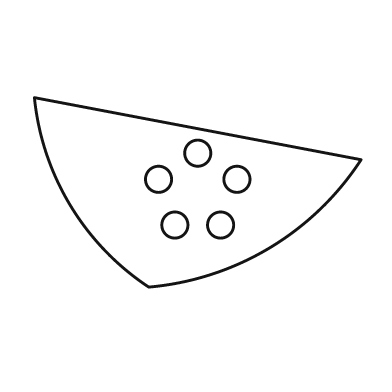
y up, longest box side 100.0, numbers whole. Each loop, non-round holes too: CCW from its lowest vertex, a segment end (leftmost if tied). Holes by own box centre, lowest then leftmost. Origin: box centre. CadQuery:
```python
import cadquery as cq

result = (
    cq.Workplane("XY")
    .moveTo(-15.0, -29.0)
    .threePointArc((22.0, -17.0), (50.0, 10.0))
    .lineTo(-50.0, 29.0)
    .threePointArc((-39.0, -4.0), (-15.0, -29.0))
    .close()
    .moveTo(-7.0, -10.0)
    .circle(4.0)
    .moveTo(7.0, -10.0)
    .circle(4.0)
    .moveTo(-12.0, 4.0)
    .circle(4.0)
    .moveTo(12.0, 4.0)
    .circle(4.0)
    .moveTo(0.0, 12.0)
    .circle(4.0)
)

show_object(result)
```